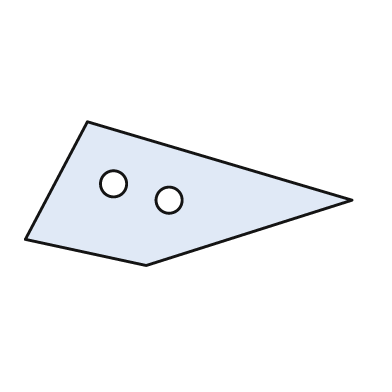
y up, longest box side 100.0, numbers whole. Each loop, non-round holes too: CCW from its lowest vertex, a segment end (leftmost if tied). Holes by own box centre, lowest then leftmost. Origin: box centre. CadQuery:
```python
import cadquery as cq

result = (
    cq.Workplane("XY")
    .moveTo(-13.0, -22.0)
    .lineTo(50.0, -2.0)
    .lineTo(-31.0, 22.0)
    .lineTo(-50.0, -14.0)
    .close()
    .moveTo(-6.0, -2.0)
    .circle(4.0)
    .moveTo(-23.0, 3.0)
    .circle(4.0)
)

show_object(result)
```